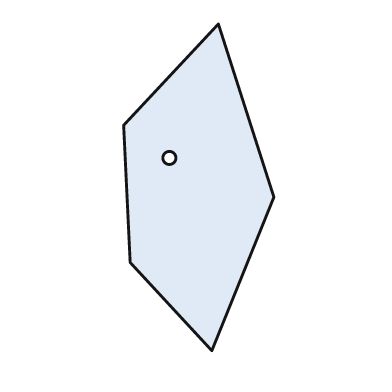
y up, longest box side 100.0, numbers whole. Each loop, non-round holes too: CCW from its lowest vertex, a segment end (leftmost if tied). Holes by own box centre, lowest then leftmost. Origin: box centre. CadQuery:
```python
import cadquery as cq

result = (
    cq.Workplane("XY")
    .moveTo(4.0, -50.0)
    .lineTo(23.0, -3.0)
    .lineTo(6.0, 50.0)
    .lineTo(-23.0, 19.0)
    .lineTo(-21.0, -23.0)
    .close()
    .moveTo(-9.0, 9.0)
    .circle(2.0)
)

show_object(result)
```